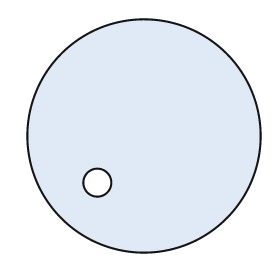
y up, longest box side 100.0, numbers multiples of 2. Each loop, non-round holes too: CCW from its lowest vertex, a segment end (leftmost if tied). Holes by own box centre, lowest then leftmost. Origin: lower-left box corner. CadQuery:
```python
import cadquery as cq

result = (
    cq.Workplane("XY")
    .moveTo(50.0, 50.0)
    .circle(50.0)
    .moveTo(30.0, 30.0)
    .circle(6.0)
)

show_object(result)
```